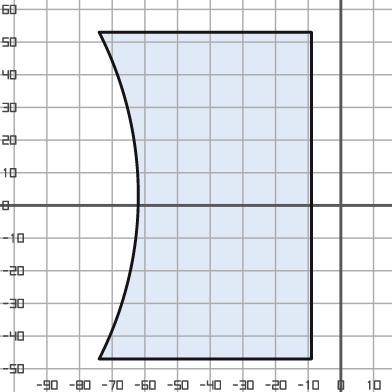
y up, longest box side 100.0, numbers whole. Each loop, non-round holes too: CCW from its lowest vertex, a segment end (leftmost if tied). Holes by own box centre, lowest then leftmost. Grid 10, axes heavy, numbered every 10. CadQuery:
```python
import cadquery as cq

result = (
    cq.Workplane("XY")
    .moveTo(-74.0, -47.0)
    .lineTo(-9.0, -47.0)
    .lineTo(-9.0, 53.0)
    .lineTo(-74.0, 53.0)
    .threePointArc((-62.0, 3.0), (-74.0, -47.0))
    .close()
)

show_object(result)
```